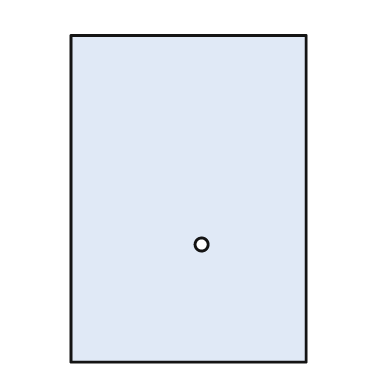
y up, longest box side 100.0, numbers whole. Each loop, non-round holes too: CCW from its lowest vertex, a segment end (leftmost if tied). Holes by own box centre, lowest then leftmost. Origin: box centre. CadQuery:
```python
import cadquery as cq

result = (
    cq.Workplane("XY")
    .moveTo(-36.0, -50.0)
    .lineTo(36.0, -50.0)
    .lineTo(36.0, 50.0)
    .lineTo(-36.0, 50.0)
    .close()
    .moveTo(4.0, -14.0)
    .circle(2.0)
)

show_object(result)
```